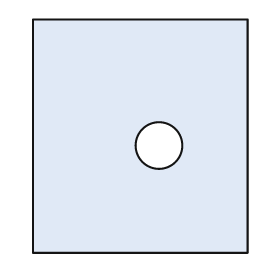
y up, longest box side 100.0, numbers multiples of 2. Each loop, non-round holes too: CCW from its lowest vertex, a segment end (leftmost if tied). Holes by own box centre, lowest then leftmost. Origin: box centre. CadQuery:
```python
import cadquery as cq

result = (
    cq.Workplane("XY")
    .moveTo(-46.0, -50.0)
    .lineTo(46.0, -50.0)
    .lineTo(46.0, 50.0)
    .lineTo(-46.0, 50.0)
    .close()
    .moveTo(8.0, -4.0)
    .circle(10.0)
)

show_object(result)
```